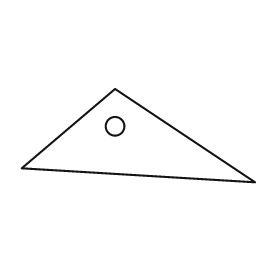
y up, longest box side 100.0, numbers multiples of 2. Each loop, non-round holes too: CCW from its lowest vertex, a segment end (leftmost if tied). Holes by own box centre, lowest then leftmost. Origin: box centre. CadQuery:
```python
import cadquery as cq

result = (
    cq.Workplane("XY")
    .moveTo(50.0, -20.0)
    .lineTo(-10.0, 20.0)
    .lineTo(-50.0, -14.0)
    .close()
    .moveTo(-10.0, 4.0)
    .circle(4.0)
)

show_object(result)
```